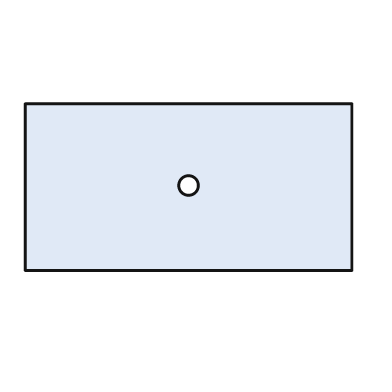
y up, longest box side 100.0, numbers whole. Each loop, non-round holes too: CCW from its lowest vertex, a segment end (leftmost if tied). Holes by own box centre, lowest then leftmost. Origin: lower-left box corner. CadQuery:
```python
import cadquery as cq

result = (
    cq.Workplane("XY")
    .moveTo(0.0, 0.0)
    .lineTo(100.0, 0.0)
    .lineTo(100.0, 51.0)
    .lineTo(0.0, 51.0)
    .close()
    .moveTo(50.0, 26.0)
    .circle(3.0)
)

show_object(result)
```